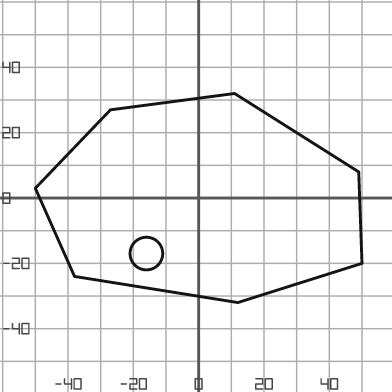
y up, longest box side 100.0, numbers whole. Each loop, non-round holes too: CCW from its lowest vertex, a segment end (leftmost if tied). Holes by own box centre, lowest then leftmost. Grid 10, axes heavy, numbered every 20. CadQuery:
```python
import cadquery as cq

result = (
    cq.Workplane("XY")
    .moveTo(12.0, -32.0)
    .lineTo(50.0, -20.0)
    .lineTo(49.0, 8.0)
    .lineTo(11.0, 32.0)
    .lineTo(-27.0, 27.0)
    .lineTo(-50.0, 3.0)
    .lineTo(-38.0, -24.0)
    .close()
    .moveTo(-16.0, -17.0)
    .circle(5.0)
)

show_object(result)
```